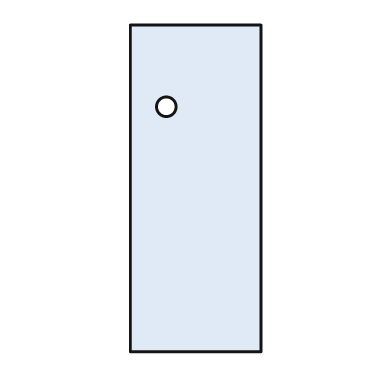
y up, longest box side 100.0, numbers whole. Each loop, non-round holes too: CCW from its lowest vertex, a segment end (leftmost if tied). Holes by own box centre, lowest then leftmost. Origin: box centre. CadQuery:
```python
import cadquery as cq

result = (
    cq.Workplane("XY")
    .moveTo(-20.0, -50.0)
    .lineTo(20.0, -50.0)
    .lineTo(20.0, 50.0)
    .lineTo(-20.0, 50.0)
    .close()
    .moveTo(-9.0, 25.0)
    .circle(3.0)
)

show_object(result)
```